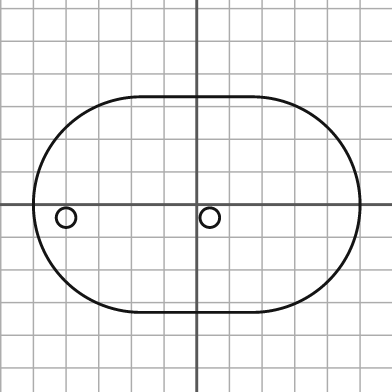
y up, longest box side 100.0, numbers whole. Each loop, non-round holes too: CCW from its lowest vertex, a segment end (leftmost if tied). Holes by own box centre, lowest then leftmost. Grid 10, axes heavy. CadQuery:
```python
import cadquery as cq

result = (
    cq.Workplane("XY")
    .moveTo(-17.0, -33.0)
    .lineTo(17.0, -33.0)
    .threePointArc((50.0, 0.0), (17.0, 33.0))
    .lineTo(-17.0, 33.0)
    .threePointArc((-50.0, 0.0), (-17.0, -33.0))
    .close()
    .moveTo(-40.0, -4.0)
    .circle(3.0)
    .moveTo(4.0, -4.0)
    .circle(3.0)
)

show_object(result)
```